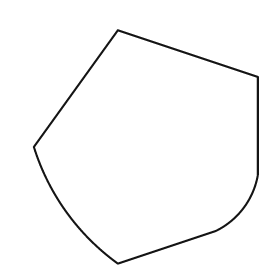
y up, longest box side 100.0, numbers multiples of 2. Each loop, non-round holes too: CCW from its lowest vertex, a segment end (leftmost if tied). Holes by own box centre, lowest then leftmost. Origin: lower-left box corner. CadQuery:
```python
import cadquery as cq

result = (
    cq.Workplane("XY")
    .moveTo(36.0, 0.0)
    .lineTo(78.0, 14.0)
    .threePointArc((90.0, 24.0), (96.0, 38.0))
    .lineTo(96.0, 80.0)
    .lineTo(36.0, 100.0)
    .lineTo(0.0, 50.0)
    .threePointArc((14.0, 22.0), (36.0, 0.0))
    .close()
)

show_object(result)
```